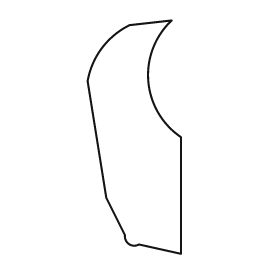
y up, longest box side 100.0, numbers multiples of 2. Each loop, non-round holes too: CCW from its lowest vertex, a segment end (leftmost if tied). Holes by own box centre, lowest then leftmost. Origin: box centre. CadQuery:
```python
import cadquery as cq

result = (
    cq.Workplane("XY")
    .moveTo(20.0, -50.0)
    .lineTo(20.0, 0.0)
    .threePointArc((6.0, 24.0), (16.0, 50.0))
    .lineTo(-2.0, 48.0)
    .threePointArc((-14.0, 38.0), (-20.0, 24.0))
    .lineTo(-12.0, -26.0)
    .lineTo(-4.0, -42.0)
    .threePointArc((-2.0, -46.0), (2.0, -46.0))
    .close()
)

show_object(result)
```